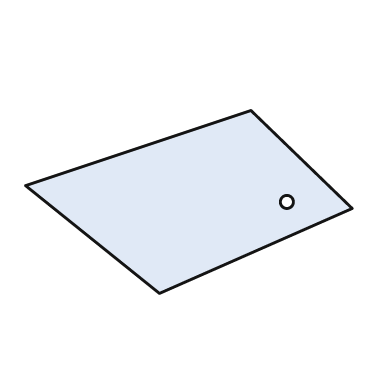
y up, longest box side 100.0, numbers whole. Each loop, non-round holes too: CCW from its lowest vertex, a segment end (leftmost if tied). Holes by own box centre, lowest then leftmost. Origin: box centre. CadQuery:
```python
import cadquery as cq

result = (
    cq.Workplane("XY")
    .moveTo(-9.0, -28.0)
    .lineTo(50.0, -2.0)
    .lineTo(19.0, 28.0)
    .lineTo(-50.0, 5.0)
    .close()
    .moveTo(30.0, 0.0)
    .circle(2.0)
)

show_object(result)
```